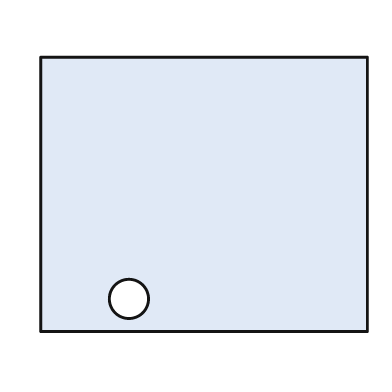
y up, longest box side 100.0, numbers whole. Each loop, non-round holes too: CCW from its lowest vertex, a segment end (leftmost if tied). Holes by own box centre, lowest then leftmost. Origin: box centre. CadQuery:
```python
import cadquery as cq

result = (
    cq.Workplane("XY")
    .moveTo(-50.0, -42.0)
    .lineTo(50.0, -42.0)
    .lineTo(50.0, 42.0)
    .lineTo(-50.0, 42.0)
    .close()
    .moveTo(-23.0, -32.0)
    .circle(6.0)
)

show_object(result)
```